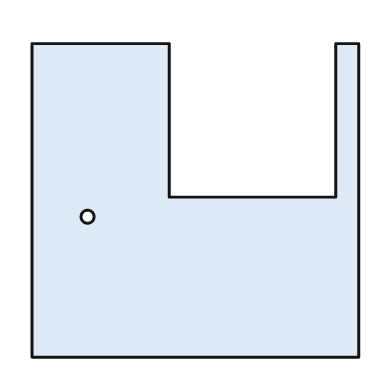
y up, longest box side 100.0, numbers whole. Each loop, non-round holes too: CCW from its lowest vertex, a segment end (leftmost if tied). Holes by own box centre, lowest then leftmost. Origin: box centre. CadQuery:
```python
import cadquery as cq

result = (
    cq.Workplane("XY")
    .moveTo(-50.0, -48.0)
    .lineTo(50.0, -48.0)
    .lineTo(50.0, 48.0)
    .lineTo(43.0, 48.0)
    .lineTo(43.0, 1.0)
    .lineTo(-8.0, 1.0)
    .lineTo(-8.0, 48.0)
    .lineTo(-50.0, 48.0)
    .close()
    .moveTo(-33.0, -5.0)
    .circle(2.0)
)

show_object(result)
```